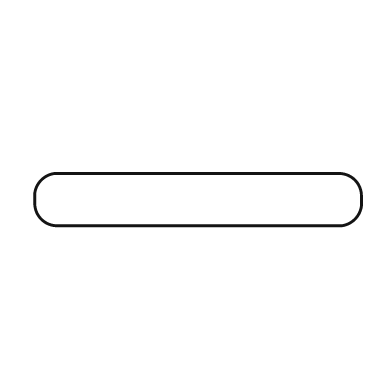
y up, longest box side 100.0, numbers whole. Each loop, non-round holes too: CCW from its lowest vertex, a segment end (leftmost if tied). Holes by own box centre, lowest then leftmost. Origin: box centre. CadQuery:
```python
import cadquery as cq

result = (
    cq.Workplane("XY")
    .moveTo(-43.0, -8.0)
    .lineTo(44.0, -8.0)
    .threePointArc((48.0, -6.0), (50.0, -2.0))
    .lineTo(50.0, 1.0)
    .threePointArc((48.0, 6.0), (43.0, 8.0))
    .lineTo(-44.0, 8.0)
    .threePointArc((-48.0, 6.0), (-50.0, 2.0))
    .lineTo(-50.0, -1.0)
    .threePointArc((-48.0, -6.0), (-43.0, -8.0))
    .close()
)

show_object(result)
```